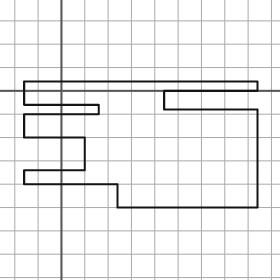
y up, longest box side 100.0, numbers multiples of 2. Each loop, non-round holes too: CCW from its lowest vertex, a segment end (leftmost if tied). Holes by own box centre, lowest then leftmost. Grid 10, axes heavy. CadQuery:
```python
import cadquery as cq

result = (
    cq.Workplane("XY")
    .moveTo(24.0, -50.0)
    .lineTo(84.0, -50.0)
    .lineTo(84.0, -8.0)
    .lineTo(44.0, -8.0)
    .lineTo(44.0, 0.0)
    .lineTo(84.0, 0.0)
    .lineTo(84.0, 4.0)
    .lineTo(-16.0, 4.0)
    .lineTo(-16.0, -6.0)
    .lineTo(16.0, -6.0)
    .lineTo(16.0, -10.0)
    .lineTo(-16.0, -10.0)
    .lineTo(-16.0, -20.0)
    .lineTo(10.0, -20.0)
    .lineTo(10.0, -34.0)
    .lineTo(-16.0, -34.0)
    .lineTo(-16.0, -40.0)
    .lineTo(24.0, -40.0)
    .close()
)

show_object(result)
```